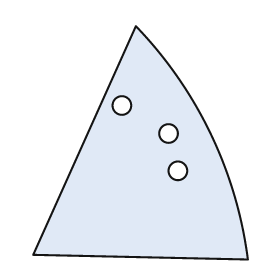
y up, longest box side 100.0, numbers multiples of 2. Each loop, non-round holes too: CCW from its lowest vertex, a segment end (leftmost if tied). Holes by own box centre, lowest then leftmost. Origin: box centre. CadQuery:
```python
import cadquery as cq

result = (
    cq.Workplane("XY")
    .moveTo(46.0, -50.0)
    .threePointArc((30.0, 4.0), (-2.0, 50.0))
    .lineTo(-46.0, -48.0)
    .close()
    .moveTo(16.0, -12.0)
    .circle(4.0)
    .moveTo(12.0, 4.0)
    .circle(4.0)
    .moveTo(-8.0, 16.0)
    .circle(4.0)
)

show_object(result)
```